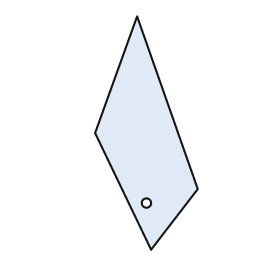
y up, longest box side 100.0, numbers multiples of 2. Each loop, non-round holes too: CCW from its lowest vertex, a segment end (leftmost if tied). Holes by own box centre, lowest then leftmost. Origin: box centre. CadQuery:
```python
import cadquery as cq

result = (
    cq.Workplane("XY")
    .moveTo(2.0, -50.0)
    .lineTo(22.0, -24.0)
    .lineTo(-4.0, 50.0)
    .lineTo(-22.0, 0.0)
    .close()
    .moveTo(0.0, -30.0)
    .circle(2.0)
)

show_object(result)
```